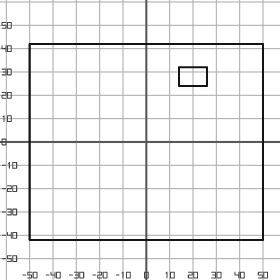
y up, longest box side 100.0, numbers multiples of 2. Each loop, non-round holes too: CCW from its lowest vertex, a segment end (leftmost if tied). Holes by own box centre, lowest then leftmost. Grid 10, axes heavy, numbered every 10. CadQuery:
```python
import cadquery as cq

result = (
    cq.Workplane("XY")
    .moveTo(-50.0, -42.0)
    .lineTo(50.0, -42.0)
    .lineTo(50.0, 42.0)
    .lineTo(-50.0, 42.0)
    .close()
    .moveTo(14.0, 24.0)
    .lineTo(26.0, 24.0)
    .lineTo(26.0, 32.0)
    .lineTo(14.0, 32.0)
    .close()
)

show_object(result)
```